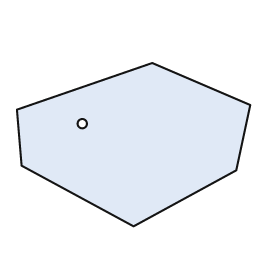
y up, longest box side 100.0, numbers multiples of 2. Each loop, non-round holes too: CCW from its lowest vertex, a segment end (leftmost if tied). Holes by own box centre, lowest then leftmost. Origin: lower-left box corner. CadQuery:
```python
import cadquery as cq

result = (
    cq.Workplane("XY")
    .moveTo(50.0, 0.0)
    .lineTo(94.0, 24.0)
    .lineTo(100.0, 52.0)
    .lineTo(58.0, 70.0)
    .lineTo(0.0, 50.0)
    .lineTo(2.0, 26.0)
    .close()
    .moveTo(28.0, 44.0)
    .circle(2.0)
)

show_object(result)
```